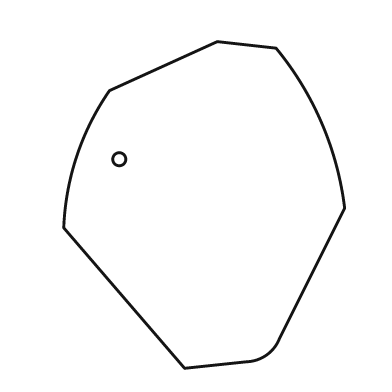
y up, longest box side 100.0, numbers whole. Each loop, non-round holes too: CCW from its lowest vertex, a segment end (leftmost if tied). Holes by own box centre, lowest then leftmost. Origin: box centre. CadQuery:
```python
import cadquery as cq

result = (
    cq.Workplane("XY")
    .moveTo(-6.0, -50.0)
    .lineTo(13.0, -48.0)
    .threePointArc((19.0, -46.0), (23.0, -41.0))
    .lineTo(43.0, -1.0)
    .threePointArc((36.0, 25.0), (22.0, 48.0))
    .lineTo(4.0, 50.0)
    .lineTo(-29.0, 35.0)
    .threePointArc((-39.0, 15.0), (-43.0, -7.0))
    .close()
    .moveTo(-26.0, 14.0)
    .circle(2.0)
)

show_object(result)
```